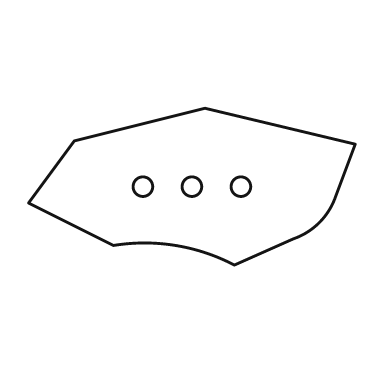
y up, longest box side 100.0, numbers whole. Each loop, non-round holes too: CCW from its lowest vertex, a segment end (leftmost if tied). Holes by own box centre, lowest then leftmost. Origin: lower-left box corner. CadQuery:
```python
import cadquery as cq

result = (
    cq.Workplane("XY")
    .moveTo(63.0, 0.0)
    .lineTo(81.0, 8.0)
    .threePointArc((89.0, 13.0), (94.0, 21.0))
    .lineTo(100.0, 37.0)
    .lineTo(54.0, 48.0)
    .lineTo(14.0, 38.0)
    .lineTo(0.0, 19.0)
    .lineTo(26.0, 6.0)
    .threePointArc((45.0, 6.0), (63.0, 0.0))
    .close()
    .moveTo(35.0, 24.0)
    .circle(3.0)
    .moveTo(50.0, 24.0)
    .circle(3.0)
    .moveTo(65.0, 24.0)
    .circle(3.0)
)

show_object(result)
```